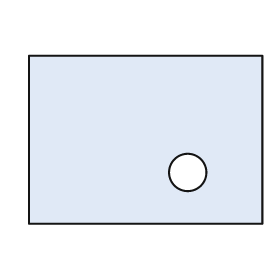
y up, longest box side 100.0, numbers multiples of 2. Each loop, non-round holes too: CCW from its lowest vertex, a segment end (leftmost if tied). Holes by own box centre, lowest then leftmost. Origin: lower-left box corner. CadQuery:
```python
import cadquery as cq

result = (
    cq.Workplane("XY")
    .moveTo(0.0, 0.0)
    .lineTo(100.0, 0.0)
    .lineTo(100.0, 72.0)
    .lineTo(0.0, 72.0)
    .close()
    .moveTo(68.0, 22.0)
    .circle(8.0)
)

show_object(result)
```